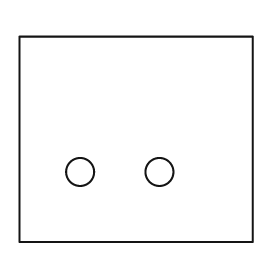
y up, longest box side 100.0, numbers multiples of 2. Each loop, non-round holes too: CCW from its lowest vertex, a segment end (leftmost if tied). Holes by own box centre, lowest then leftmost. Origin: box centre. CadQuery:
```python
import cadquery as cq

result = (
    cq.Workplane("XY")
    .moveTo(-50.0, -44.0)
    .lineTo(50.0, -44.0)
    .lineTo(50.0, 44.0)
    .lineTo(-50.0, 44.0)
    .close()
    .moveTo(-24.0, -14.0)
    .circle(6.0)
    .moveTo(10.0, -14.0)
    .circle(6.0)
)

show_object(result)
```